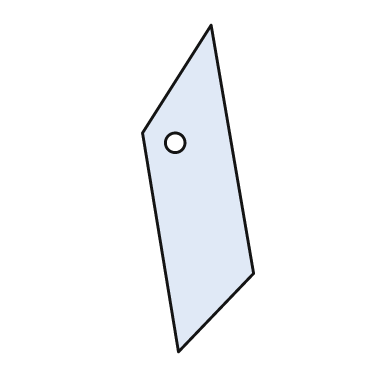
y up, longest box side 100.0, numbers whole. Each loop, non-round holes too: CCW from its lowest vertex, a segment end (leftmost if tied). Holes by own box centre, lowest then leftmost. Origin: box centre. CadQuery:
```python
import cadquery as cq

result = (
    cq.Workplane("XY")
    .moveTo(-6.0, -50.0)
    .lineTo(17.0, -26.0)
    .lineTo(4.0, 50.0)
    .lineTo(-17.0, 17.0)
    .close()
    .moveTo(-7.0, 14.0)
    .circle(3.0)
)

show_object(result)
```